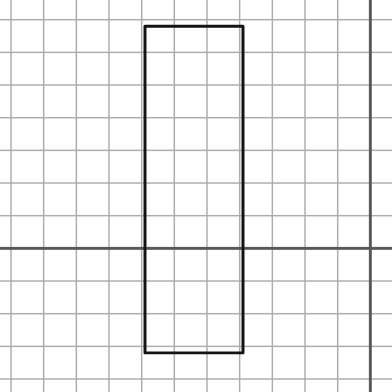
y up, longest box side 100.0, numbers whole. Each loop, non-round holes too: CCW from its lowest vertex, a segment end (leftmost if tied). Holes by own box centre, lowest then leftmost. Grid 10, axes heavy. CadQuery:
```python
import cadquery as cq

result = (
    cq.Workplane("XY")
    .moveTo(-69.0, -32.0)
    .lineTo(-39.0, -32.0)
    .lineTo(-39.0, 68.0)
    .lineTo(-69.0, 68.0)
    .close()
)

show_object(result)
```